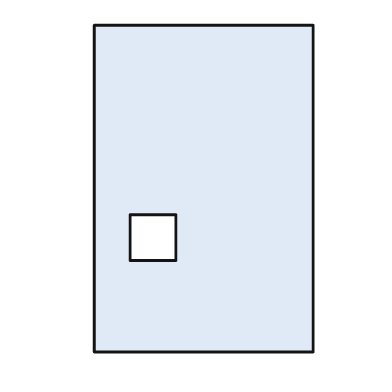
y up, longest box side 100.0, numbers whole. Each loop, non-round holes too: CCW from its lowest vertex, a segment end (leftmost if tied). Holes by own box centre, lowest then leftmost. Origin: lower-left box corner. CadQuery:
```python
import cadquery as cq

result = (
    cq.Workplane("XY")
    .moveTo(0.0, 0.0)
    .lineTo(67.0, 0.0)
    .lineTo(67.0, 100.0)
    .lineTo(0.0, 100.0)
    .close()
    .moveTo(11.0, 28.0)
    .lineTo(25.0, 28.0)
    .lineTo(25.0, 42.0)
    .lineTo(11.0, 42.0)
    .close()
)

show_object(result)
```